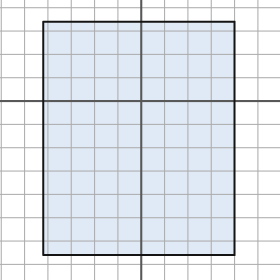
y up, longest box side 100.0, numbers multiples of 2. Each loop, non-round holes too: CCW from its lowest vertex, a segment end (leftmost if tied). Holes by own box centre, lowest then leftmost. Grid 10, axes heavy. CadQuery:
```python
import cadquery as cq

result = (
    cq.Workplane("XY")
    .moveTo(-42.0, -66.0)
    .lineTo(40.0, -66.0)
    .lineTo(40.0, 34.0)
    .lineTo(-42.0, 34.0)
    .close()
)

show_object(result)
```